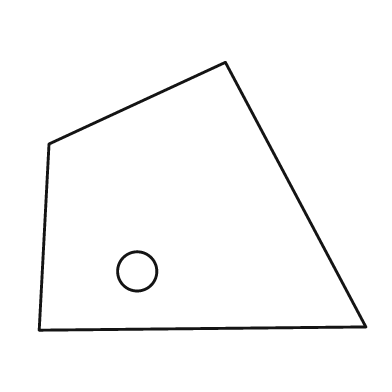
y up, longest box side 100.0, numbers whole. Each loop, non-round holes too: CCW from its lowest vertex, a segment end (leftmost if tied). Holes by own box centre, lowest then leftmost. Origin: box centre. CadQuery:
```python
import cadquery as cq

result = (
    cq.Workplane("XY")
    .moveTo(-50.0, -41.0)
    .lineTo(50.0, -40.0)
    .lineTo(7.0, 41.0)
    .lineTo(-47.0, 16.0)
    .close()
    .moveTo(-20.0, -23.0)
    .circle(6.0)
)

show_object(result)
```